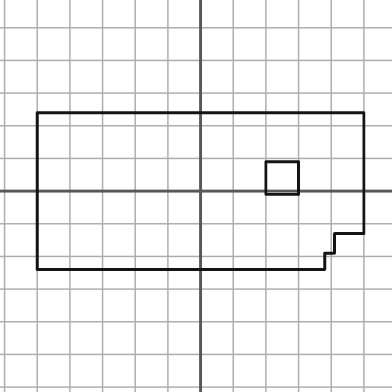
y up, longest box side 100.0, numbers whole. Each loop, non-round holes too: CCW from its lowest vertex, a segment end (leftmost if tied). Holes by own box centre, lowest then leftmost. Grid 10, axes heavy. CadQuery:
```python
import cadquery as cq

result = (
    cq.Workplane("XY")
    .moveTo(-50.0, -24.0)
    .lineTo(38.0, -24.0)
    .lineTo(38.0, -19.0)
    .lineTo(41.0, -19.0)
    .lineTo(41.0, -13.0)
    .lineTo(50.0, -13.0)
    .lineTo(50.0, 24.0)
    .lineTo(-50.0, 24.0)
    .close()
    .moveTo(20.0, -1.0)
    .lineTo(30.0, -1.0)
    .lineTo(30.0, 9.0)
    .lineTo(20.0, 9.0)
    .close()
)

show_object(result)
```